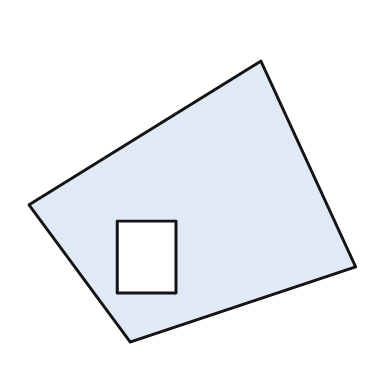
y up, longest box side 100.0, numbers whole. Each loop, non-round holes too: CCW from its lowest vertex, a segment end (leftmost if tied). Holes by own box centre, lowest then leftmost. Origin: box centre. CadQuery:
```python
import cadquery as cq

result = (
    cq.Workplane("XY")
    .moveTo(-19.0, -43.0)
    .lineTo(50.0, -20.0)
    .lineTo(21.0, 43.0)
    .lineTo(-50.0, -1.0)
    .close()
    .moveTo(-23.0, -28.0)
    .lineTo(-5.0, -28.0)
    .lineTo(-5.0, -6.0)
    .lineTo(-23.0, -6.0)
    .close()
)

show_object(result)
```